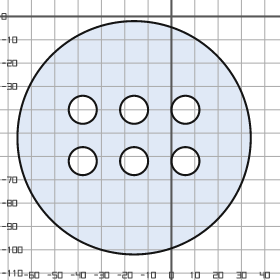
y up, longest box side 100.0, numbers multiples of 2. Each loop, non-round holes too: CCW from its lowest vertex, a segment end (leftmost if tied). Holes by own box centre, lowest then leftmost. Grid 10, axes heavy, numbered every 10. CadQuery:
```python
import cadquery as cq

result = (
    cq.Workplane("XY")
    .moveTo(-16.0, -52.0)
    .circle(50.0)
    .moveTo(-38.0, -62.0)
    .circle(6.0)
    .moveTo(-16.0, -62.0)
    .circle(6.0)
    .moveTo(6.0, -62.0)
    .circle(6.0)
    .moveTo(-38.0, -40.0)
    .circle(6.0)
    .moveTo(-16.0, -40.0)
    .circle(6.0)
    .moveTo(6.0, -40.0)
    .circle(6.0)
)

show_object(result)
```